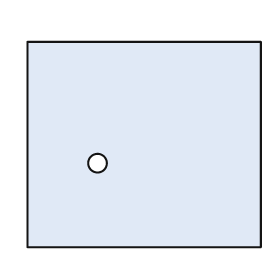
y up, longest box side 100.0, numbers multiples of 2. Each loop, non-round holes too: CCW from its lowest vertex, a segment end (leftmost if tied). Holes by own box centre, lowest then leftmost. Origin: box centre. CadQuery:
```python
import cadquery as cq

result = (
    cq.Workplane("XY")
    .moveTo(-50.0, -44.0)
    .lineTo(50.0, -44.0)
    .lineTo(50.0, 44.0)
    .lineTo(-50.0, 44.0)
    .close()
    .moveTo(-20.0, -8.0)
    .circle(4.0)
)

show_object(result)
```